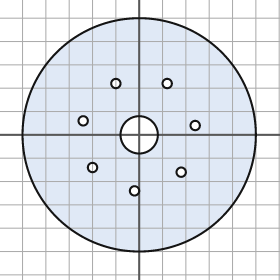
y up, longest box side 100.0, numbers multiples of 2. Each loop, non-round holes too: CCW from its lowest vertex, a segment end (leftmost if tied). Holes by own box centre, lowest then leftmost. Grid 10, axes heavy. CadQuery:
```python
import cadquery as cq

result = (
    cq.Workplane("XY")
    .moveTo(0.0, 0.0)
    .circle(50.0)
    .moveTo(-2.0, -24.0)
    .circle(2.0)
    .moveTo(18.0, -16.0)
    .circle(2.0)
    .moveTo(-20.0, -14.0)
    .circle(2.0)
    .moveTo(0.0, 0.0)
    .circle(8.0)
    .moveTo(24.0, 4.0)
    .circle(2.0)
    .moveTo(-24.0, 6.0)
    .circle(2.0)
    .moveTo(-10.0, 22.0)
    .circle(2.0)
    .moveTo(12.0, 22.0)
    .circle(2.0)
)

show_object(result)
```